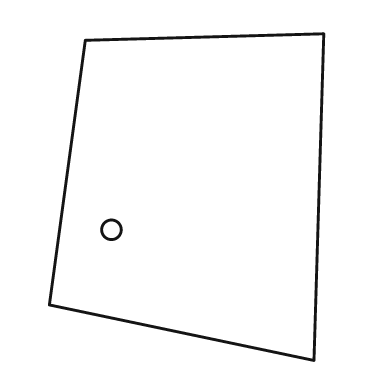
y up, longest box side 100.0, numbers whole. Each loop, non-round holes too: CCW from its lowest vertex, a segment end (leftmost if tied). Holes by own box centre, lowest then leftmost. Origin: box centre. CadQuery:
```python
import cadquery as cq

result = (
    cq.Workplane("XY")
    .moveTo(39.0, -50.0)
    .lineTo(42.0, 50.0)
    .lineTo(-31.0, 48.0)
    .lineTo(-42.0, -33.0)
    .close()
    .moveTo(-23.0, -10.0)
    .circle(3.0)
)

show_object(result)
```